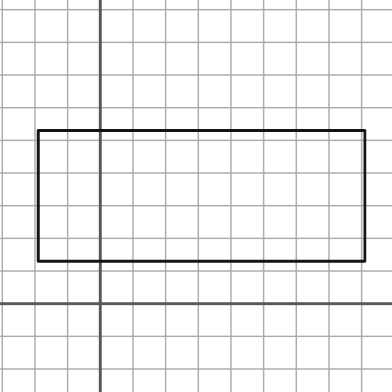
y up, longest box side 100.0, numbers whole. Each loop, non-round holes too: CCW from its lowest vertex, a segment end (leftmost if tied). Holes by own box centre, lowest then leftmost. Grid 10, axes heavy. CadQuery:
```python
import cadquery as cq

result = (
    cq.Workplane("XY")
    .moveTo(-19.0, 13.0)
    .lineTo(81.0, 13.0)
    .lineTo(81.0, 53.0)
    .lineTo(-19.0, 53.0)
    .close()
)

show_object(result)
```